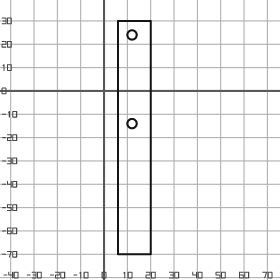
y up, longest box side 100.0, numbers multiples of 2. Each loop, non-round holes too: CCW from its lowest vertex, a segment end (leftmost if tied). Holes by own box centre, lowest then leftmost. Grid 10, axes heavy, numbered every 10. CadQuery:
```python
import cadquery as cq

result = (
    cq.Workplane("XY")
    .moveTo(6.0, -70.0)
    .lineTo(20.0, -70.0)
    .lineTo(20.0, 30.0)
    .lineTo(6.0, 30.0)
    .close()
    .moveTo(12.0, -14.0)
    .circle(2.0)
    .moveTo(12.0, 24.0)
    .circle(2.0)
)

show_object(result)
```